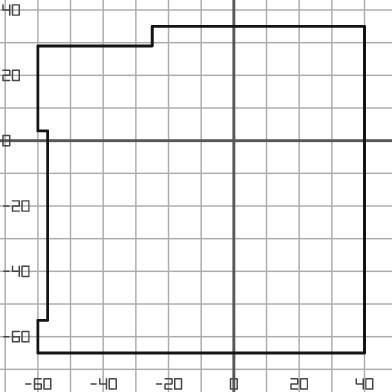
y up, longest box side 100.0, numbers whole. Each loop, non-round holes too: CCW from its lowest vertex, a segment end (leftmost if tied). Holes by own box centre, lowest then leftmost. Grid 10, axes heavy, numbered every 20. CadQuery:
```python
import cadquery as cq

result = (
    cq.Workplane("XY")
    .moveTo(-60.0, -65.0)
    .lineTo(40.0, -65.0)
    .lineTo(40.0, 35.0)
    .lineTo(-25.0, 35.0)
    .lineTo(-25.0, 29.0)
    .lineTo(-60.0, 29.0)
    .lineTo(-60.0, 3.0)
    .lineTo(-57.0, 3.0)
    .lineTo(-57.0, -55.0)
    .lineTo(-60.0, -55.0)
    .close()
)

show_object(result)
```